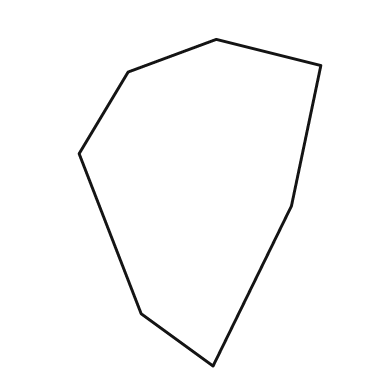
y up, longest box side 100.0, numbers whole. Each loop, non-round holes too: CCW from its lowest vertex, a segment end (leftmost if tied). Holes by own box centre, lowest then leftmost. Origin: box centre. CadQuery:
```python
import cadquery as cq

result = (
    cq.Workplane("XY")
    .moveTo(4.0, -50.0)
    .lineTo(28.0, -1.0)
    .lineTo(37.0, 42.0)
    .lineTo(5.0, 50.0)
    .lineTo(-22.0, 40.0)
    .lineTo(-37.0, 15.0)
    .lineTo(-18.0, -34.0)
    .close()
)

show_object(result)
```